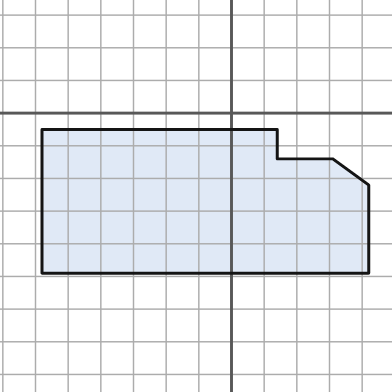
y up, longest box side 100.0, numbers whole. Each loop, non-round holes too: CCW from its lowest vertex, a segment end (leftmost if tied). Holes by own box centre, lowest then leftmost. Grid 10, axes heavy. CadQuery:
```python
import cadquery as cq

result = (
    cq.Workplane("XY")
    .moveTo(-58.0, -49.0)
    .lineTo(42.0, -49.0)
    .lineTo(42.0, -22.0)
    .lineTo(31.0, -14.0)
    .lineTo(14.0, -14.0)
    .lineTo(14.0, -5.0)
    .lineTo(-58.0, -5.0)
    .close()
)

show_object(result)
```